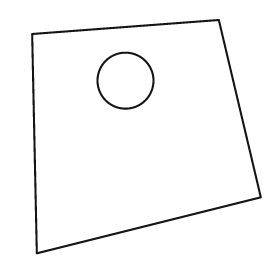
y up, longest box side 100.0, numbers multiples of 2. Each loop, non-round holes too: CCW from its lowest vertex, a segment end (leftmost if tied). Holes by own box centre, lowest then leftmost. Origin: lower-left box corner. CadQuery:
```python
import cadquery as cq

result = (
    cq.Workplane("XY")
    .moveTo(2.0, 0.0)
    .lineTo(98.0, 24.0)
    .lineTo(80.0, 100.0)
    .lineTo(0.0, 94.0)
    .close()
    .moveTo(40.0, 74.0)
    .circle(12.0)
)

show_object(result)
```